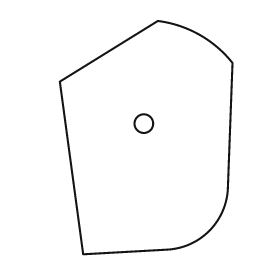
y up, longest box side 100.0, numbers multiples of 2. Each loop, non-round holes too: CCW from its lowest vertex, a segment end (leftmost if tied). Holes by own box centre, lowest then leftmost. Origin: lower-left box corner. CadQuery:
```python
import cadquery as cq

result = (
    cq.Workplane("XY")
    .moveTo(10.0, 0.0)
    .lineTo(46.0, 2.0)
    .threePointArc((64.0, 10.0), (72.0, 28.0))
    .lineTo(74.0, 82.0)
    .threePointArc((60.0, 94.0), (42.0, 100.0))
    .lineTo(0.0, 74.0)
    .close()
    .moveTo(36.0, 56.0)
    .circle(4.0)
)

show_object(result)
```